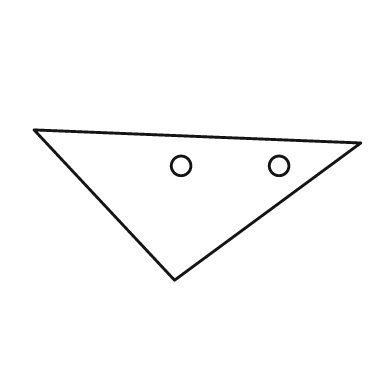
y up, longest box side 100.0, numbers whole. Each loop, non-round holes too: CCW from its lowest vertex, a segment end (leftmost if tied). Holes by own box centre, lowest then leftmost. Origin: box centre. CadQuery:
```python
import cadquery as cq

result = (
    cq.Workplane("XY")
    .moveTo(-7.0, -23.0)
    .lineTo(50.0, 19.0)
    .lineTo(-50.0, 23.0)
    .close()
    .moveTo(-5.0, 12.0)
    .circle(3.0)
    .moveTo(25.0, 12.0)
    .circle(3.0)
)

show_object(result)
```